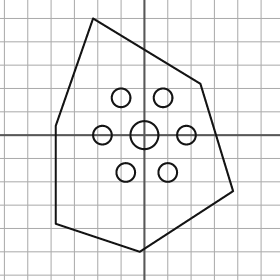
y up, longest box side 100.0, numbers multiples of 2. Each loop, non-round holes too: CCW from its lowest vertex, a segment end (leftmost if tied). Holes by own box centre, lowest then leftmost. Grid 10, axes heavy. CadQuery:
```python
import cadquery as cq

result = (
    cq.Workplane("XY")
    .moveTo(-2.0, -50.0)
    .lineTo(38.0, -24.0)
    .lineTo(24.0, 22.0)
    .lineTo(-22.0, 50.0)
    .lineTo(-38.0, 4.0)
    .lineTo(-38.0, -38.0)
    .close()
    .moveTo(-8.0, -16.0)
    .circle(4.0)
    .moveTo(10.0, -16.0)
    .circle(4.0)
    .moveTo(-18.0, 0.0)
    .circle(4.0)
    .moveTo(0.0, 0.0)
    .circle(6.0)
    .moveTo(18.0, 0.0)
    .circle(4.0)
    .moveTo(-10.0, 16.0)
    .circle(4.0)
    .moveTo(8.0, 16.0)
    .circle(4.0)
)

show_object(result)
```